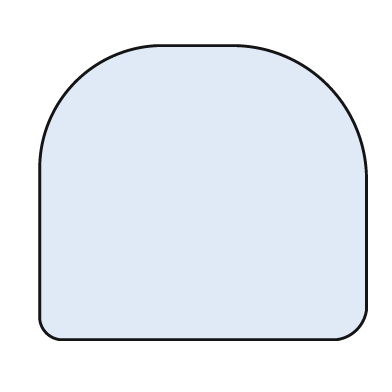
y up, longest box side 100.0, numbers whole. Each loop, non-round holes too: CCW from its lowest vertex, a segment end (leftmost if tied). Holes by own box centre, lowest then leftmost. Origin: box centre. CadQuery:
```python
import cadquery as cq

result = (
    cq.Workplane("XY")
    .moveTo(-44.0, -45.0)
    .lineTo(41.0, -45.0)
    .threePointArc((47.0, -42.0), (50.0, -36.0))
    .lineTo(50.0, 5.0)
    .threePointArc((38.0, 33.0), (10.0, 45.0))
    .lineTo(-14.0, 45.0)
    .threePointArc((-39.0, 34.0), (-50.0, 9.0))
    .lineTo(-50.0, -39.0)
    .threePointArc((-48.0, -43.0), (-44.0, -45.0))
    .close()
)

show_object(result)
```